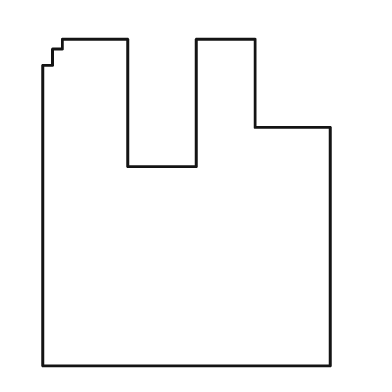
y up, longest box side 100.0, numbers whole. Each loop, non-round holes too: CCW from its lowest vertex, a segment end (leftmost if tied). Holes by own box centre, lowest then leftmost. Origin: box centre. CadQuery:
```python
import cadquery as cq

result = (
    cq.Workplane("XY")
    .moveTo(-44.0, -50.0)
    .lineTo(44.0, -50.0)
    .lineTo(44.0, 23.0)
    .lineTo(21.0, 23.0)
    .lineTo(21.0, 50.0)
    .lineTo(3.0, 50.0)
    .lineTo(3.0, 11.0)
    .lineTo(-18.0, 11.0)
    .lineTo(-18.0, 50.0)
    .lineTo(-38.0, 50.0)
    .lineTo(-38.0, 47.0)
    .lineTo(-41.0, 47.0)
    .lineTo(-41.0, 42.0)
    .lineTo(-44.0, 42.0)
    .close()
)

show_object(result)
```